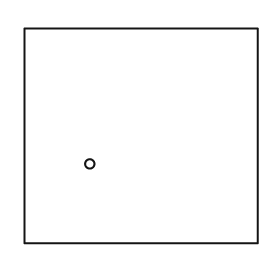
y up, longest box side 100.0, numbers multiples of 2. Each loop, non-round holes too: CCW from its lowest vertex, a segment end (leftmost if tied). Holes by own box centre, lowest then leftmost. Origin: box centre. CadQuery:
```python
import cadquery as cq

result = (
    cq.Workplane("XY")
    .moveTo(-50.0, -46.0)
    .lineTo(50.0, -46.0)
    .lineTo(50.0, 46.0)
    .lineTo(-50.0, 46.0)
    .close()
    .moveTo(-22.0, -12.0)
    .circle(2.0)
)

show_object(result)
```